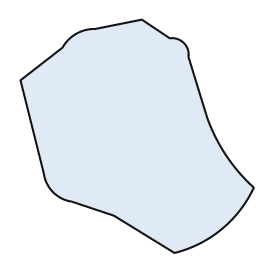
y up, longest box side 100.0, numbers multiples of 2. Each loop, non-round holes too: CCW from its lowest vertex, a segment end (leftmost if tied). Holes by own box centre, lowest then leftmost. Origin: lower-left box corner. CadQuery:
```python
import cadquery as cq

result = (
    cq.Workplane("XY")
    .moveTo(66.0, 0.0)
    .threePointArc((86.0, 10.0), (100.0, 28.0))
    .threePointArc((88.0, 42.0), (80.0, 58.0))
    .lineTo(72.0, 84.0)
    .threePointArc((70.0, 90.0), (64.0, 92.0))
    .lineTo(52.0, 100.0)
    .lineTo(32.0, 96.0)
    .threePointArc((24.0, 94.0), (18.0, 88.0))
    .lineTo(0.0, 74.0)
    .lineTo(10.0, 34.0)
    .threePointArc((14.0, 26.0), (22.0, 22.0))
    .lineTo(40.0, 16.0)
    .close()
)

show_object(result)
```